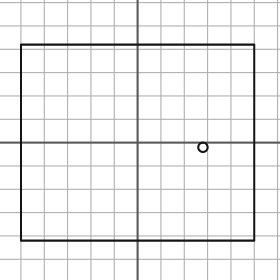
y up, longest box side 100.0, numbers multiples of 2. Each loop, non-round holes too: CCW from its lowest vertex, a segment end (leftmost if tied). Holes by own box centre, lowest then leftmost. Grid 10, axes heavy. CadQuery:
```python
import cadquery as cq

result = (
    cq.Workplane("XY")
    .moveTo(-50.0, -42.0)
    .lineTo(50.0, -42.0)
    .lineTo(50.0, 42.0)
    .lineTo(-50.0, 42.0)
    .close()
    .moveTo(28.0, -2.0)
    .circle(2.0)
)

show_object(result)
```